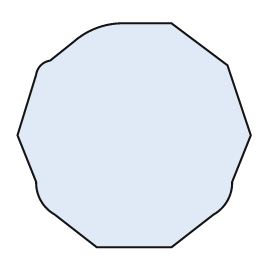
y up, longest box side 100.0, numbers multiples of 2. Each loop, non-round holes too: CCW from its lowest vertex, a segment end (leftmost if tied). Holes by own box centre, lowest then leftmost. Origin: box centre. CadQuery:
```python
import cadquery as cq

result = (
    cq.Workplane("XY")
    .moveTo(-16.0, -48.0)
    .lineTo(16.0, -48.0)
    .lineTo(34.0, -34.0)
    .threePointArc((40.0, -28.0), (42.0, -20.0))
    .lineTo(50.0, 0.0)
    .lineTo(40.0, 30.0)
    .lineTo(16.0, 48.0)
    .lineTo(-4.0, 48.0)
    .threePointArc((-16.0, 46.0), (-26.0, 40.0))
    .lineTo(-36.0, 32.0)
    .threePointArc((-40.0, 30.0), (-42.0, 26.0))
    .lineTo(-50.0, 0.0)
    .lineTo(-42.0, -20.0)
    .threePointArc((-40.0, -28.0), (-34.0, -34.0))
    .close()
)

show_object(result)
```